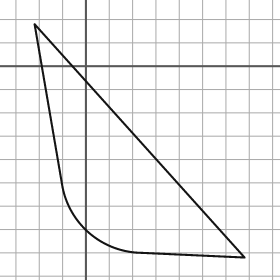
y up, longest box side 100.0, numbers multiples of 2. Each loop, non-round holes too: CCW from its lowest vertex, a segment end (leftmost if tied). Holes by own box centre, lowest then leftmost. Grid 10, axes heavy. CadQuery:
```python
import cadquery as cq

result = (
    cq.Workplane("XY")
    .moveTo(68.0, -82.0)
    .lineTo(-22.0, 18.0)
    .lineTo(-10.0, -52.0)
    .threePointArc((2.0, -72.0), (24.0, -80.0))
    .close()
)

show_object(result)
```